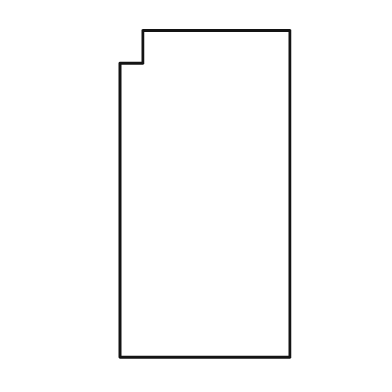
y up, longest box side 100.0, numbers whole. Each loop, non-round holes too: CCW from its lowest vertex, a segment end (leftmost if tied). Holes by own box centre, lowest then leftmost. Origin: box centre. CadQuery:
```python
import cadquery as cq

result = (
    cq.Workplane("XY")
    .moveTo(-26.0, -50.0)
    .lineTo(26.0, -50.0)
    .lineTo(26.0, 50.0)
    .lineTo(-19.0, 50.0)
    .lineTo(-19.0, 40.0)
    .lineTo(-26.0, 40.0)
    .close()
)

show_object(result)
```